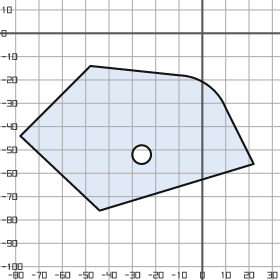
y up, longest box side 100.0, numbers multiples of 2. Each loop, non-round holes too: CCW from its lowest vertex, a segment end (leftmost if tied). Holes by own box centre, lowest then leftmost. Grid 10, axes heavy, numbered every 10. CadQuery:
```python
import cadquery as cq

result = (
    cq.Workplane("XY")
    .moveTo(-44.0, -76.0)
    .lineTo(22.0, -56.0)
    .lineTo(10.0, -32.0)
    .threePointArc((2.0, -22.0), (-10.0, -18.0))
    .lineTo(-48.0, -14.0)
    .lineTo(-78.0, -44.0)
    .close()
    .moveTo(-26.0, -52.0)
    .circle(4.0)
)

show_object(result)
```